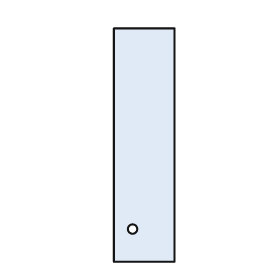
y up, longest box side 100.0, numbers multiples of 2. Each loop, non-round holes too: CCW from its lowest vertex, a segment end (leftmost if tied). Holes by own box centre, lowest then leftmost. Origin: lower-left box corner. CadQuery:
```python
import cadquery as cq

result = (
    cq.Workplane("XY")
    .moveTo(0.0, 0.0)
    .lineTo(26.0, 0.0)
    .lineTo(26.0, 100.0)
    .lineTo(0.0, 100.0)
    .close()
    .moveTo(8.0, 14.0)
    .circle(2.0)
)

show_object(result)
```